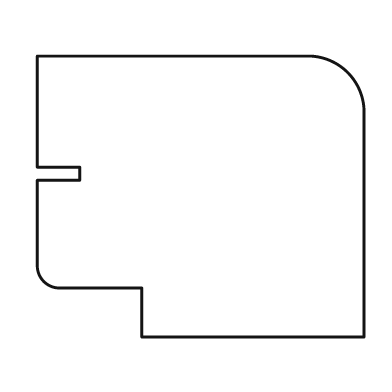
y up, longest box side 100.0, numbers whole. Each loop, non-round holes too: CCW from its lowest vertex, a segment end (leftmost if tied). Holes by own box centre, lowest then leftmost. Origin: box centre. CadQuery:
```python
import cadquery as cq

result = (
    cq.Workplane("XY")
    .moveTo(-18.0, -43.0)
    .lineTo(50.0, -43.0)
    .lineTo(50.0, 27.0)
    .threePointArc((45.0, 38.0), (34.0, 43.0))
    .lineTo(-50.0, 43.0)
    .lineTo(-50.0, 9.0)
    .lineTo(-37.0, 9.0)
    .lineTo(-37.0, 5.0)
    .lineTo(-50.0, 5.0)
    .lineTo(-50.0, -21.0)
    .threePointArc((-48.0, -26.0), (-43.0, -28.0))
    .lineTo(-18.0, -28.0)
    .close()
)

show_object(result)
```